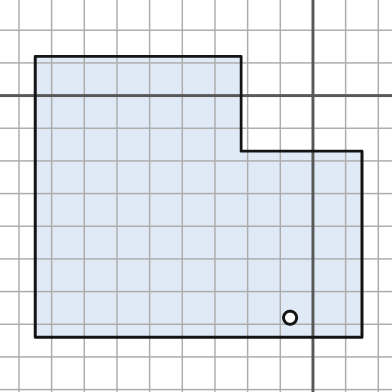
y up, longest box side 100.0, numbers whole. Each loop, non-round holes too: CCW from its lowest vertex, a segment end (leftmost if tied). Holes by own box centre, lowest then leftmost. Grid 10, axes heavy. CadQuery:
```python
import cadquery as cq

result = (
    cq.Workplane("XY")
    .moveTo(-85.0, -74.0)
    .lineTo(15.0, -74.0)
    .lineTo(15.0, -17.0)
    .lineTo(-22.0, -17.0)
    .lineTo(-22.0, 12.0)
    .lineTo(-85.0, 12.0)
    .close()
    .moveTo(-7.0, -68.0)
    .circle(2.0)
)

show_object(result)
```